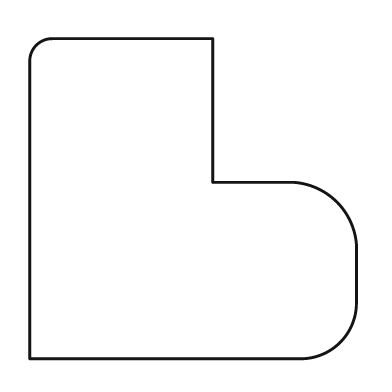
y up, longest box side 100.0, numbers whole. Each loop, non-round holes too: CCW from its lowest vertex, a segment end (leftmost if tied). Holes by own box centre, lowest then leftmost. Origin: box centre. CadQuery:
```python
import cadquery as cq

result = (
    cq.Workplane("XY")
    .moveTo(-50.0, -49.0)
    .lineTo(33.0, -49.0)
    .threePointArc((45.0, -44.0), (50.0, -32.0))
    .lineTo(50.0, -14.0)
    .threePointArc((44.0, -1.0), (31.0, 5.0))
    .lineTo(6.0, 5.0)
    .lineTo(6.0, 49.0)
    .lineTo(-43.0, 49.0)
    .threePointArc((-48.0, 47.0), (-50.0, 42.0))
    .close()
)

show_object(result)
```